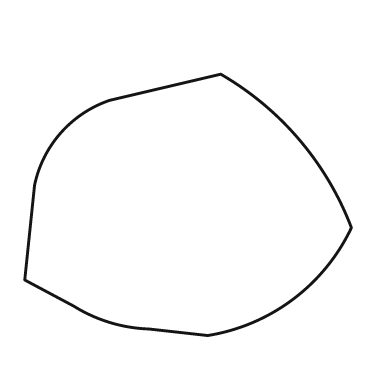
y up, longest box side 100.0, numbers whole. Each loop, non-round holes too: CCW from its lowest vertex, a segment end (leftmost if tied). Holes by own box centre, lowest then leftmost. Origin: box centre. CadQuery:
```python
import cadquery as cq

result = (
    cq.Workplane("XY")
    .moveTo(6.0, -40.0)
    .threePointArc((32.0, -29.0), (50.0, -7.0))
    .threePointArc((34.0, 20.0), (10.0, 40.0))
    .lineTo(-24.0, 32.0)
    .threePointArc((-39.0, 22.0), (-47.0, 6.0))
    .lineTo(-50.0, -23.0)
    .lineTo(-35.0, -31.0)
    .threePointArc((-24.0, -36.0), (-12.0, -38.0))
    .close()
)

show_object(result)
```